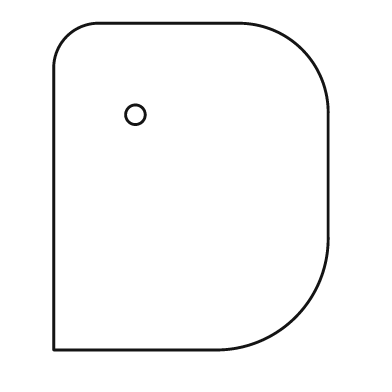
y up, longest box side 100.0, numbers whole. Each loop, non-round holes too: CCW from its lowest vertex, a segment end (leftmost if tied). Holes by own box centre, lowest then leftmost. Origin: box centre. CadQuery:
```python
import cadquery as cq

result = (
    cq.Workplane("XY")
    .moveTo(-42.0, -50.0)
    .lineTo(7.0, -50.0)
    .threePointArc((32.0, -40.0), (42.0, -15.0))
    .lineTo(42.0, 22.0)
    .threePointArc((34.0, 42.0), (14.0, 50.0))
    .lineTo(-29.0, 50.0)
    .threePointArc((-38.0, 46.0), (-42.0, 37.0))
    .close()
    .moveTo(-17.0, 22.0)
    .circle(3.0)
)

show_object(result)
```